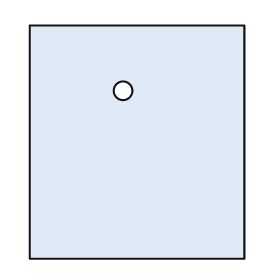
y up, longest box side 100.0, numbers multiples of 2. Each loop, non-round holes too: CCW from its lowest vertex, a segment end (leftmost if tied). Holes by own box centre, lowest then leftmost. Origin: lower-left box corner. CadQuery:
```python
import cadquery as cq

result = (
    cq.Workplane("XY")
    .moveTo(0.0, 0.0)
    .lineTo(92.0, 0.0)
    .lineTo(92.0, 100.0)
    .lineTo(0.0, 100.0)
    .close()
    .moveTo(40.0, 72.0)
    .circle(4.0)
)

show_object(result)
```